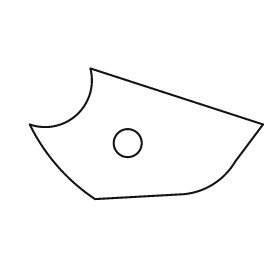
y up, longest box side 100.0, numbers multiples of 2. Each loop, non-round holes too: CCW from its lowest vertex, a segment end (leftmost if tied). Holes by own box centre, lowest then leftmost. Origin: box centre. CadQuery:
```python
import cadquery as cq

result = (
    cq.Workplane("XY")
    .moveTo(-22.0, -28.0)
    .lineTo(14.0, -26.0)
    .threePointArc((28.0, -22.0), (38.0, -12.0))
    .lineTo(50.0, 4.0)
    .lineTo(-24.0, 28.0)
    .threePointArc((-30.0, 8.0), (-50.0, 4.0))
    .threePointArc((-38.0, -14.0), (-22.0, -28.0))
    .close()
    .moveTo(-8.0, -4.0)
    .circle(6.0)
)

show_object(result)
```